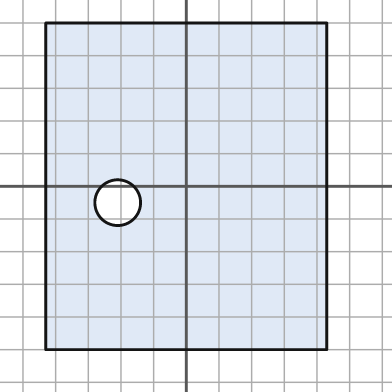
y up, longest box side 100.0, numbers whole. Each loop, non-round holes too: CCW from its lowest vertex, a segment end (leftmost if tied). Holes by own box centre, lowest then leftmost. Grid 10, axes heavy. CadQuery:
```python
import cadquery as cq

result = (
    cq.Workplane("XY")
    .moveTo(-43.0, -50.0)
    .lineTo(43.0, -50.0)
    .lineTo(43.0, 50.0)
    .lineTo(-43.0, 50.0)
    .close()
    .moveTo(-21.0, -5.0)
    .circle(7.0)
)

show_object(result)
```